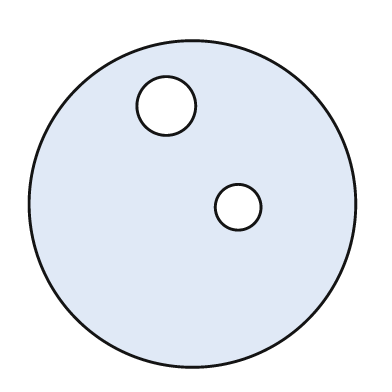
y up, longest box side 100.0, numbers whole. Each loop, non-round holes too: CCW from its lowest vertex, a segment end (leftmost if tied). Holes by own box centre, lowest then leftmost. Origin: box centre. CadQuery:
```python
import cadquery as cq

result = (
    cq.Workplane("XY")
    .moveTo(0.0, 0.0)
    .circle(50.0)
    .moveTo(14.0, -1.0)
    .circle(7.0)
    .moveTo(-8.0, 30.0)
    .circle(9.0)
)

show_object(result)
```